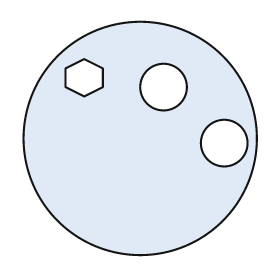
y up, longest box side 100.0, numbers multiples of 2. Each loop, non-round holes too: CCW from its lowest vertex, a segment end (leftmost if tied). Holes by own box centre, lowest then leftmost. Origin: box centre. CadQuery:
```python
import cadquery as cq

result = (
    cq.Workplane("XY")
    .moveTo(0.0, 0.0)
    .circle(50.0)
    .moveTo(36.0, -2.0)
    .circle(10.0)
    .moveTo(10.0, 22.0)
    .circle(10.0)
    .moveTo(-24.0, 18.0)
    .lineTo(-16.0, 22.0)
    .lineTo(-16.0, 30.0)
    .lineTo(-24.0, 34.0)
    .lineTo(-32.0, 30.0)
    .lineTo(-32.0, 22.0)
    .close()
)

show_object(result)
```